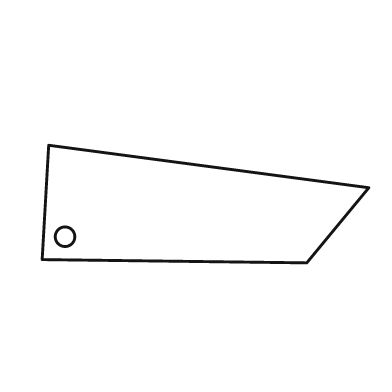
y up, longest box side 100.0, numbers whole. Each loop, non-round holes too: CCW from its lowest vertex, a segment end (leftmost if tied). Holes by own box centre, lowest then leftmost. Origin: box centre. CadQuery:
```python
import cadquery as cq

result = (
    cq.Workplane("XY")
    .moveTo(31.0, -18.0)
    .lineTo(50.0, 5.0)
    .lineTo(-48.0, 18.0)
    .lineTo(-50.0, -17.0)
    .close()
    .moveTo(-43.0, -10.0)
    .circle(3.0)
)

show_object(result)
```